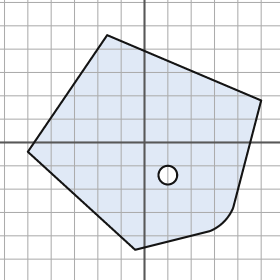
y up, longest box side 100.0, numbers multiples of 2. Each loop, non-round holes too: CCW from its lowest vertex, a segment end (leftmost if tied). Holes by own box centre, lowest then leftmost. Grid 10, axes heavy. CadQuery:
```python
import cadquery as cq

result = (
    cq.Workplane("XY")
    .moveTo(-4.0, -46.0)
    .lineTo(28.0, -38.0)
    .threePointArc((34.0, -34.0), (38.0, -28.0))
    .lineTo(50.0, 18.0)
    .lineTo(-16.0, 46.0)
    .lineTo(-50.0, -4.0)
    .close()
    .moveTo(10.0, -14.0)
    .circle(4.0)
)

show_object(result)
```